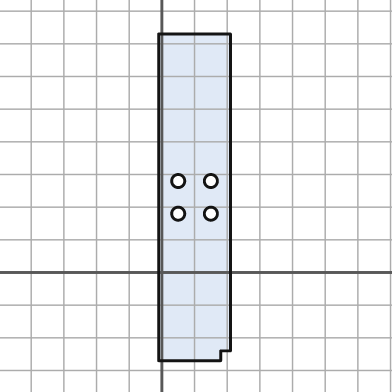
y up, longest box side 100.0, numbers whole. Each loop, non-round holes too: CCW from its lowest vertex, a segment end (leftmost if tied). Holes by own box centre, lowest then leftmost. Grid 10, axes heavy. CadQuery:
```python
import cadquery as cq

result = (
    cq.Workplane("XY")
    .moveTo(-1.0, -27.0)
    .lineTo(18.0, -27.0)
    .lineTo(18.0, -24.0)
    .lineTo(21.0, -24.0)
    .lineTo(21.0, 73.0)
    .lineTo(-1.0, 73.0)
    .close()
    .moveTo(5.0, 18.0)
    .circle(2.0)
    .moveTo(15.0, 18.0)
    .circle(2.0)
    .moveTo(5.0, 28.0)
    .circle(2.0)
    .moveTo(15.0, 28.0)
    .circle(2.0)
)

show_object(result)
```